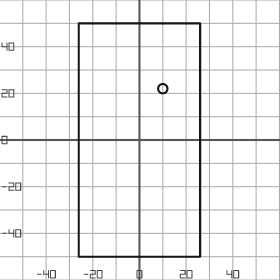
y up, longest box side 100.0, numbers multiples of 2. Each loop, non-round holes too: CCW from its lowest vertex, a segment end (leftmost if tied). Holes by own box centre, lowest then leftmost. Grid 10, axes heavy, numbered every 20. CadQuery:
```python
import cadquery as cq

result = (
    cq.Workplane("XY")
    .moveTo(-26.0, -50.0)
    .lineTo(26.0, -50.0)
    .lineTo(26.0, 50.0)
    .lineTo(-26.0, 50.0)
    .close()
    .moveTo(10.0, 22.0)
    .circle(2.0)
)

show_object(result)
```